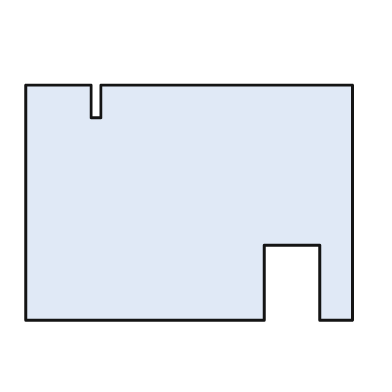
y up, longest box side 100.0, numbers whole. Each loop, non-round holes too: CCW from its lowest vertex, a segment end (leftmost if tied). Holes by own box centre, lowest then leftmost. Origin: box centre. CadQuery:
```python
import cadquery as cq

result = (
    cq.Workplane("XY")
    .moveTo(-50.0, -36.0)
    .lineTo(23.0, -36.0)
    .lineTo(23.0, -13.0)
    .lineTo(40.0, -13.0)
    .lineTo(40.0, -36.0)
    .lineTo(50.0, -36.0)
    .lineTo(50.0, 36.0)
    .lineTo(-27.0, 36.0)
    .lineTo(-27.0, 26.0)
    .lineTo(-30.0, 26.0)
    .lineTo(-30.0, 36.0)
    .lineTo(-50.0, 36.0)
    .close()
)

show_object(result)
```